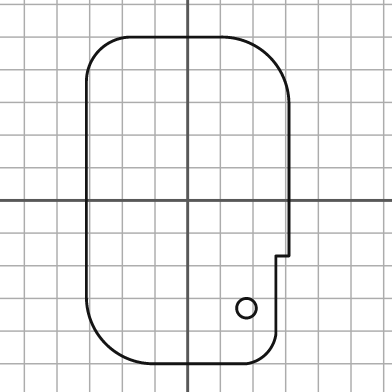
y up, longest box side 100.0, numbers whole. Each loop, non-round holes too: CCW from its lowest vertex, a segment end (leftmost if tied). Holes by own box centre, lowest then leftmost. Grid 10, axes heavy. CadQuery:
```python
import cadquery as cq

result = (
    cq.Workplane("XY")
    .moveTo(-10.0, -50.0)
    .lineTo(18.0, -50.0)
    .threePointArc((24.0, -47.0), (27.0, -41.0))
    .lineTo(27.0, -17.0)
    .lineTo(31.0, -17.0)
    .lineTo(31.0, 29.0)
    .threePointArc((25.0, 44.0), (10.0, 50.0))
    .lineTo(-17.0, 50.0)
    .threePointArc((-27.0, 46.0), (-31.0, 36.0))
    .lineTo(-31.0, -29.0)
    .threePointArc((-25.0, -44.0), (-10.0, -50.0))
    .close()
    .moveTo(18.0, -33.0)
    .circle(3.0)
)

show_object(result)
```